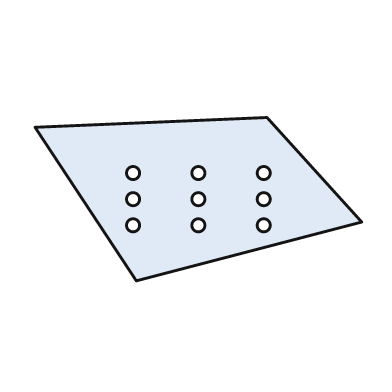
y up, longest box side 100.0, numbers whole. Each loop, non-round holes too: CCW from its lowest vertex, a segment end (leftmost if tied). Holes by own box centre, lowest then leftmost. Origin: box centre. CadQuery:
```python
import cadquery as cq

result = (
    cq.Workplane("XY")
    .moveTo(-19.0, -25.0)
    .lineTo(50.0, -7.0)
    .lineTo(21.0, 25.0)
    .lineTo(-50.0, 22.0)
    .close()
    .moveTo(-20.0, -8.0)
    .circle(2.0)
    .moveTo(0.0, -8.0)
    .circle(2.0)
    .moveTo(20.0, -8.0)
    .circle(2.0)
    .moveTo(-20.0, 0.0)
    .circle(2.0)
    .moveTo(0.0, 0.0)
    .circle(2.0)
    .moveTo(20.0, 0.0)
    .circle(2.0)
    .moveTo(-20.0, 8.0)
    .circle(2.0)
    .moveTo(0.0, 8.0)
    .circle(2.0)
    .moveTo(20.0, 8.0)
    .circle(2.0)
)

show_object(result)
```